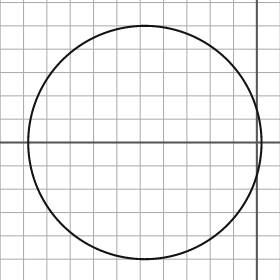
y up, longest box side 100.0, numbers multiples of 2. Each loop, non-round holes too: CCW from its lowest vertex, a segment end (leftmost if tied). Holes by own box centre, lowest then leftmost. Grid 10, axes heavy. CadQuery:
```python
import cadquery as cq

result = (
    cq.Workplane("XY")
    .moveTo(-48.0, 0.0)
    .circle(50.0)
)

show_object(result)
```